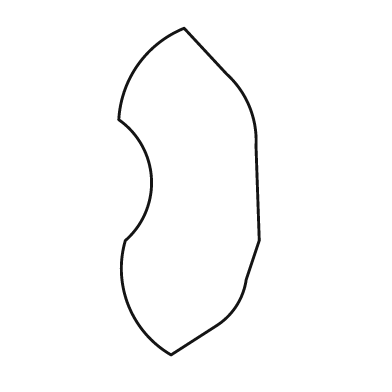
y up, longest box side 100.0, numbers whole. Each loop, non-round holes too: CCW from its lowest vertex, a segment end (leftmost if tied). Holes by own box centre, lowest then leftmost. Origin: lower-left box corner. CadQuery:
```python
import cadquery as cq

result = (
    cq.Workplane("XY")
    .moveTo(16.0, 0.0)
    .lineTo(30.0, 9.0)
    .threePointArc((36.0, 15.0), (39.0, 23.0))
    .lineTo(43.0, 35.0)
    .lineTo(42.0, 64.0)
    .threePointArc((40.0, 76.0), (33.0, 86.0))
    .lineTo(20.0, 100.0)
    .threePointArc((6.0, 89.0), (0.0, 72.0))
    .threePointArc((10.0, 54.0), (2.0, 35.0))
    .threePointArc((3.0, 15.0), (16.0, 0.0))
    .close()
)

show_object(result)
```